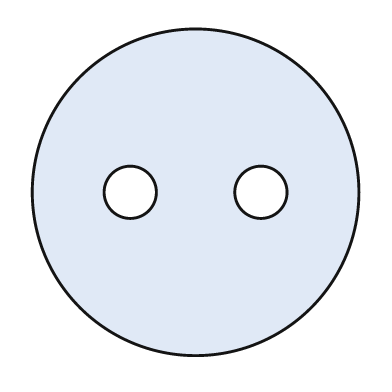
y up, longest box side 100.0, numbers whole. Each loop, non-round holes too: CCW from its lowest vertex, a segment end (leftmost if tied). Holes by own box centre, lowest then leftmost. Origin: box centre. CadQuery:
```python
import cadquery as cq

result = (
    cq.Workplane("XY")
    .moveTo(0.0, 0.0)
    .circle(50.0)
    .moveTo(-20.0, 0.0)
    .circle(8.0)
    .moveTo(20.0, 0.0)
    .circle(8.0)
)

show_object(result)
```